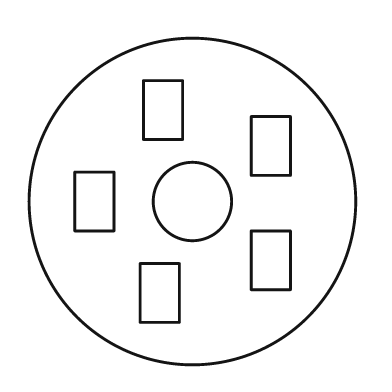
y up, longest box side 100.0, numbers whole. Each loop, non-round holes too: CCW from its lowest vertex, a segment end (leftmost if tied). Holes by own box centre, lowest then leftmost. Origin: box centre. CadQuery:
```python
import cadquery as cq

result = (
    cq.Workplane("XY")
    .moveTo(0.0, 0.0)
    .circle(50.0)
    .moveTo(-16.0, -37.0)
    .lineTo(-4.0, -37.0)
    .lineTo(-4.0, -19.0)
    .lineTo(-16.0, -19.0)
    .close()
    .moveTo(18.0, -27.0)
    .lineTo(30.0, -27.0)
    .lineTo(30.0, -9.0)
    .lineTo(18.0, -9.0)
    .close()
    .moveTo(-36.0, -9.0)
    .lineTo(-24.0, -9.0)
    .lineTo(-24.0, 9.0)
    .lineTo(-36.0, 9.0)
    .close()
    .moveTo(0.0, 0.0)
    .circle(12.0)
    .moveTo(18.0, 8.0)
    .lineTo(30.0, 8.0)
    .lineTo(30.0, 26.0)
    .lineTo(18.0, 26.0)
    .close()
    .moveTo(-15.0, 19.0)
    .lineTo(-3.0, 19.0)
    .lineTo(-3.0, 37.0)
    .lineTo(-15.0, 37.0)
    .close()
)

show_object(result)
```